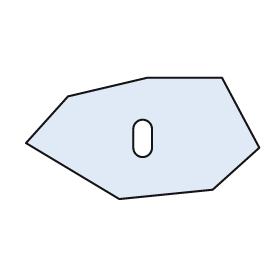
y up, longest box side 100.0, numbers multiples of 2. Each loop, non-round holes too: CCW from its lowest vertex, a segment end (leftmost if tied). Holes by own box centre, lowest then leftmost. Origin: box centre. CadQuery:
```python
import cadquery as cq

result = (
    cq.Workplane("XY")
    .moveTo(-10.0, -26.0)
    .lineTo(30.0, -22.0)
    .lineTo(50.0, -4.0)
    .lineTo(34.0, 26.0)
    .lineTo(2.0, 26.0)
    .lineTo(-32.0, 18.0)
    .lineTo(-50.0, -2.0)
    .close()
    .moveTo(-4.0, -4.0)
    .threePointArc((0.0, -8.0), (4.0, -4.0))
    .lineTo(4.0, 4.0)
    .threePointArc((0.0, 8.0), (-4.0, 4.0))
    .close()
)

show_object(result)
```